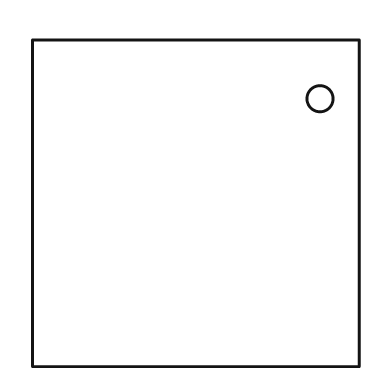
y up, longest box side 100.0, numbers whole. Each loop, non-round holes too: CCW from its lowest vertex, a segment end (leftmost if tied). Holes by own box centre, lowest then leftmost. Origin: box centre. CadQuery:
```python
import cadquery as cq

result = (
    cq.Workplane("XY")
    .moveTo(-50.0, -50.0)
    .lineTo(50.0, -50.0)
    .lineTo(50.0, 50.0)
    .lineTo(-50.0, 50.0)
    .close()
    .moveTo(38.0, 32.0)
    .circle(4.0)
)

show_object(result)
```